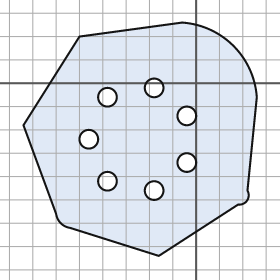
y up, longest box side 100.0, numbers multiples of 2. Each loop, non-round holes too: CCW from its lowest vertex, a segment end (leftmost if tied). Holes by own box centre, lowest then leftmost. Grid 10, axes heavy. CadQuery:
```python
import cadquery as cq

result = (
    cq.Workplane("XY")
    .moveTo(-16.0, -74.0)
    .lineTo(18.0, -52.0)
    .threePointArc((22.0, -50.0), (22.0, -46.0))
    .lineTo(26.0, -6.0)
    .threePointArc((16.0, 16.0), (-6.0, 26.0))
    .lineTo(-50.0, 20.0)
    .lineTo(-74.0, -18.0)
    .lineTo(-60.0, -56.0)
    .threePointArc((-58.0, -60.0), (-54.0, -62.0))
    .close()
    .moveTo(-18.0, -46.0)
    .circle(4.0)
    .moveTo(-38.0, -42.0)
    .circle(4.0)
    .moveTo(-4.0, -34.0)
    .circle(4.0)
    .moveTo(-46.0, -24.0)
    .circle(4.0)
    .moveTo(-4.0, -14.0)
    .circle(4.0)
    .moveTo(-38.0, -6.0)
    .circle(4.0)
    .moveTo(-18.0, -2.0)
    .circle(4.0)
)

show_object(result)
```